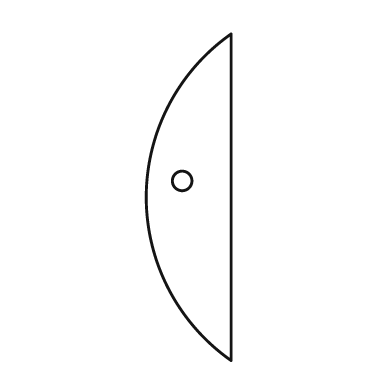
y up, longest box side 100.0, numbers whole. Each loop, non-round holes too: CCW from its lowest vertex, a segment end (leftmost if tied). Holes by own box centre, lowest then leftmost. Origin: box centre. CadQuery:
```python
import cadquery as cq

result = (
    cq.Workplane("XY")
    .moveTo(13.0, -50.0)
    .lineTo(13.0, 50.0)
    .threePointArc((-13.0, 0.0), (13.0, -50.0))
    .close()
    .moveTo(-2.0, 5.0)
    .circle(3.0)
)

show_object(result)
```